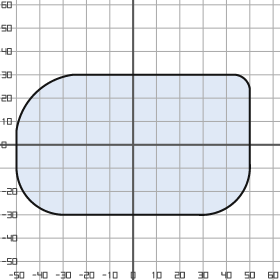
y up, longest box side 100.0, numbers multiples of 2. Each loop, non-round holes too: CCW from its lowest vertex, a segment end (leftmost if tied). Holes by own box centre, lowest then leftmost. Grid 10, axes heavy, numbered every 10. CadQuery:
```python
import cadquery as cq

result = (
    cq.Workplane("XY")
    .moveTo(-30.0, -30.0)
    .lineTo(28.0, -30.0)
    .threePointArc((44.0, -24.0), (50.0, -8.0))
    .lineTo(50.0, 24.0)
    .threePointArc((48.0, 28.0), (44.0, 30.0))
    .lineTo(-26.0, 30.0)
    .threePointArc((-42.0, 22.0), (-50.0, 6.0))
    .lineTo(-50.0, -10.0)
    .threePointArc((-44.0, -24.0), (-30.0, -30.0))
    .close()
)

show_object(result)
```